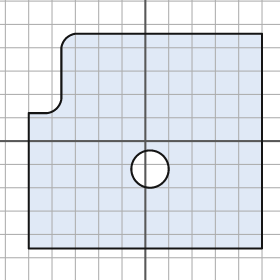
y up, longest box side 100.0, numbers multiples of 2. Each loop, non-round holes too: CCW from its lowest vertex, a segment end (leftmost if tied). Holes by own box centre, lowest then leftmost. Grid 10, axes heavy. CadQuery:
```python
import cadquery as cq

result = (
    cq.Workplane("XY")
    .moveTo(-50.0, -46.0)
    .lineTo(50.0, -46.0)
    .lineTo(50.0, 46.0)
    .lineTo(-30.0, 46.0)
    .threePointArc((-34.0, 44.0), (-36.0, 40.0))
    .lineTo(-36.0, 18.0)
    .threePointArc((-38.0, 14.0), (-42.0, 12.0))
    .lineTo(-50.0, 12.0)
    .close()
    .moveTo(2.0, -12.0)
    .circle(8.0)
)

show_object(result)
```